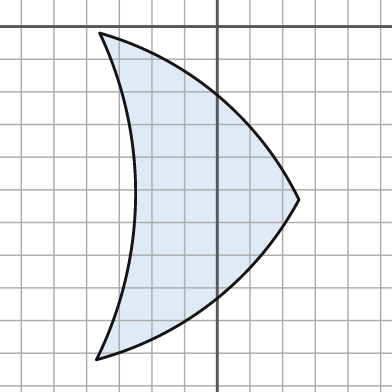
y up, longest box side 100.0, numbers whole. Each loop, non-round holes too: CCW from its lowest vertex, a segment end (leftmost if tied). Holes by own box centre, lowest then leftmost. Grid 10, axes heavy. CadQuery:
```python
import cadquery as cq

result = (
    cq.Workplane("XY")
    .moveTo(-37.0, -102.0)
    .threePointArc((-1.0, -84.0), (25.0, -53.0))
    .threePointArc((0.0, -21.0), (-36.0, -2.0))
    .threePointArc((-25.0, -52.0), (-37.0, -102.0))
    .close()
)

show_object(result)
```